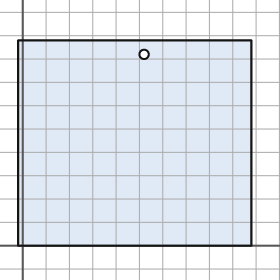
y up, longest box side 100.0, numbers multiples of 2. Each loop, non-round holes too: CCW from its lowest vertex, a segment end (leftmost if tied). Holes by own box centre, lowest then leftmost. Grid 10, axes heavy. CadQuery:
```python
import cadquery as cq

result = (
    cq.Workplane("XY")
    .moveTo(-2.0, 0.0)
    .lineTo(98.0, 0.0)
    .lineTo(98.0, 88.0)
    .lineTo(-2.0, 88.0)
    .close()
    .moveTo(52.0, 82.0)
    .circle(2.0)
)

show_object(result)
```